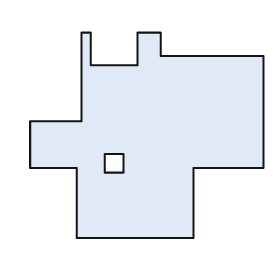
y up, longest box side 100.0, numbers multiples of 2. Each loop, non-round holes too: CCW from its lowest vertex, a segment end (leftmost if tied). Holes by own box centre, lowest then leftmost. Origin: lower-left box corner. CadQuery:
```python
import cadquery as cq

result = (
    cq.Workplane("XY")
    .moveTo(20.0, 0.0)
    .lineTo(70.0, 0.0)
    .lineTo(70.0, 30.0)
    .lineTo(100.0, 30.0)
    .lineTo(100.0, 78.0)
    .lineTo(56.0, 78.0)
    .lineTo(56.0, 88.0)
    .lineTo(46.0, 88.0)
    .lineTo(46.0, 74.0)
    .lineTo(26.0, 74.0)
    .lineTo(26.0, 88.0)
    .lineTo(22.0, 88.0)
    .lineTo(22.0, 50.0)
    .lineTo(0.0, 50.0)
    .lineTo(0.0, 30.0)
    .lineTo(20.0, 30.0)
    .close()
    .moveTo(32.0, 28.0)
    .lineTo(40.0, 28.0)
    .lineTo(40.0, 36.0)
    .lineTo(32.0, 36.0)
    .close()
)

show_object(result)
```